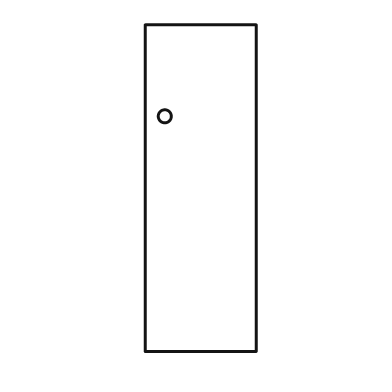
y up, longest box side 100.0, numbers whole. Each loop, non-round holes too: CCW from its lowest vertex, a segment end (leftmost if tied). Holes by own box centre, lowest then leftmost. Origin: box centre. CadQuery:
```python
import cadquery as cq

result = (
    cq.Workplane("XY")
    .moveTo(-17.0, -50.0)
    .lineTo(17.0, -50.0)
    .lineTo(17.0, 50.0)
    .lineTo(-17.0, 50.0)
    .close()
    .moveTo(-11.0, 22.0)
    .circle(2.0)
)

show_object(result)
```